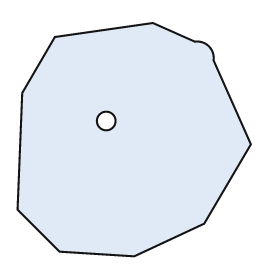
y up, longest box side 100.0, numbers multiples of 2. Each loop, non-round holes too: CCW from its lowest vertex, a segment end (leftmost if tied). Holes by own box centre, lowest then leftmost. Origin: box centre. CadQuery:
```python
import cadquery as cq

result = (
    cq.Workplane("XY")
    .moveTo(0.0, -50.0)
    .lineTo(30.0, -36.0)
    .lineTo(50.0, -2.0)
    .lineTo(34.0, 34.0)
    .threePointArc((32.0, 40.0), (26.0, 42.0))
    .lineTo(8.0, 50.0)
    .lineTo(-34.0, 44.0)
    .lineTo(-48.0, 20.0)
    .lineTo(-50.0, -30.0)
    .lineTo(-32.0, -48.0)
    .close()
    .moveTo(-12.0, 8.0)
    .circle(4.0)
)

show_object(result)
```